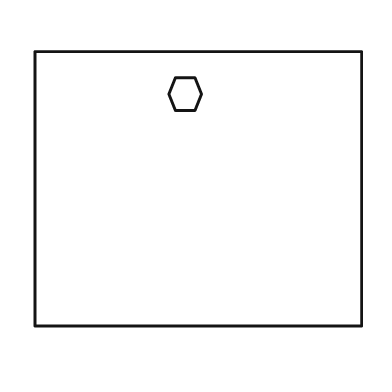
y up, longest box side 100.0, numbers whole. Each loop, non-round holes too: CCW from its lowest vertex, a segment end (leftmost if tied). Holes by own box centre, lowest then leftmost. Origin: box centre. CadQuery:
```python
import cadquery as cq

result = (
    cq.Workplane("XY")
    .moveTo(-50.0, -42.0)
    .lineTo(50.0, -42.0)
    .lineTo(50.0, 42.0)
    .lineTo(-50.0, 42.0)
    .close()
    .moveTo(-7.0, 24.0)
    .lineTo(-1.0, 24.0)
    .lineTo(1.0, 29.0)
    .lineTo(-1.0, 34.0)
    .lineTo(-7.0, 34.0)
    .lineTo(-9.0, 29.0)
    .close()
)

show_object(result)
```